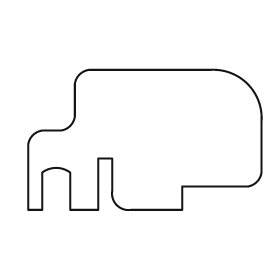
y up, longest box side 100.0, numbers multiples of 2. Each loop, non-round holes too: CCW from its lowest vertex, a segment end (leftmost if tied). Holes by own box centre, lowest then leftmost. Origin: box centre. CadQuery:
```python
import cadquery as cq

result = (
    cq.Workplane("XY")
    .moveTo(-50.0, -30.0)
    .lineTo(-44.0, -30.0)
    .lineTo(-44.0, -14.0)
    .threePointArc((-38.0, -12.0), (-32.0, -14.0))
    .lineTo(-32.0, -30.0)
    .lineTo(-20.0, -30.0)
    .lineTo(-20.0, -8.0)
    .lineTo(-14.0, -8.0)
    .lineTo(-14.0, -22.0)
    .threePointArc((-12.0, -28.0), (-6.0, -30.0))
    .lineTo(16.0, -30.0)
    .lineTo(16.0, -20.0)
    .lineTo(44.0, -20.0)
    .threePointArc((48.0, -18.0), (50.0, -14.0))
    .lineTo(50.0, 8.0)
    .threePointArc((44.0, 24.0), (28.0, 30.0))
    .lineTo(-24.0, 30.0)
    .threePointArc((-28.0, 28.0), (-30.0, 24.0))
    .lineTo(-30.0, 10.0)
    .threePointArc((-32.0, 6.0), (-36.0, 4.0))
    .lineTo(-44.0, 4.0)
    .threePointArc((-48.0, 2.0), (-50.0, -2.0))
    .close()
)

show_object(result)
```